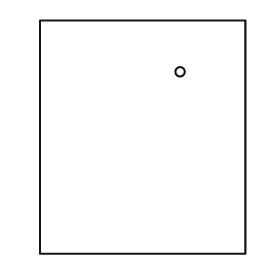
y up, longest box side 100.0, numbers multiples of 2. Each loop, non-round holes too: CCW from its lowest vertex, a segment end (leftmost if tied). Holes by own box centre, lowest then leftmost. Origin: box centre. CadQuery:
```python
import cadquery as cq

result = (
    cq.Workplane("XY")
    .moveTo(-44.0, -50.0)
    .lineTo(44.0, -50.0)
    .lineTo(44.0, 50.0)
    .lineTo(-44.0, 50.0)
    .close()
    .moveTo(16.0, 28.0)
    .circle(2.0)
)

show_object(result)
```